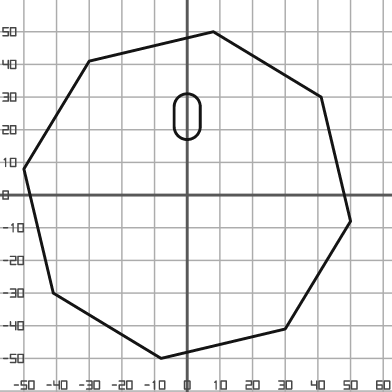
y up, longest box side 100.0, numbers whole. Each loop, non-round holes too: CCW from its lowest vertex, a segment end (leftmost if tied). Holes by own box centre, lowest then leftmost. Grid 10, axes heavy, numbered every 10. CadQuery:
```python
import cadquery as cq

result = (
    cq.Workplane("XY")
    .moveTo(-8.0, -50.0)
    .lineTo(30.0, -41.0)
    .lineTo(50.0, -8.0)
    .lineTo(41.0, 30.0)
    .lineTo(8.0, 50.0)
    .lineTo(-30.0, 41.0)
    .lineTo(-50.0, 8.0)
    .lineTo(-41.0, -30.0)
    .close()
    .moveTo(-4.0, 21.0)
    .threePointArc((0.0, 17.0), (4.0, 21.0))
    .lineTo(4.0, 27.0)
    .threePointArc((0.0, 31.0), (-4.0, 27.0))
    .close()
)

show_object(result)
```